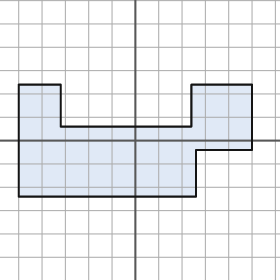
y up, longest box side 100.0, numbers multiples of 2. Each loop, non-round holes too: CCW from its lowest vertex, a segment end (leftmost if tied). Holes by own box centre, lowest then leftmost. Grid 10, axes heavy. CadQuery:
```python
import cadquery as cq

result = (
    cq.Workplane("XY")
    .moveTo(-50.0, -24.0)
    .lineTo(26.0, -24.0)
    .lineTo(26.0, -4.0)
    .lineTo(50.0, -4.0)
    .lineTo(50.0, 24.0)
    .lineTo(24.0, 24.0)
    .lineTo(24.0, 6.0)
    .lineTo(-32.0, 6.0)
    .lineTo(-32.0, 24.0)
    .lineTo(-50.0, 24.0)
    .close()
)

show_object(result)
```